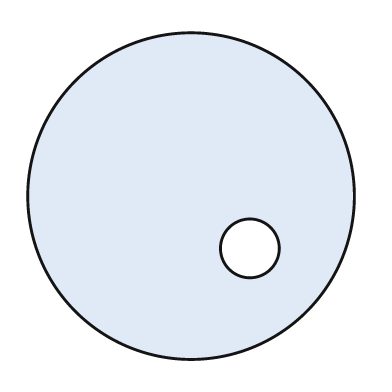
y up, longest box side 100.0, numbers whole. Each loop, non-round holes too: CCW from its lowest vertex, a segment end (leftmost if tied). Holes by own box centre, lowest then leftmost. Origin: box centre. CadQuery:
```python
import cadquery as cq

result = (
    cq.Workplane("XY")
    .moveTo(0.0, 0.0)
    .circle(50.0)
    .moveTo(18.0, -16.0)
    .circle(9.0)
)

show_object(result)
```